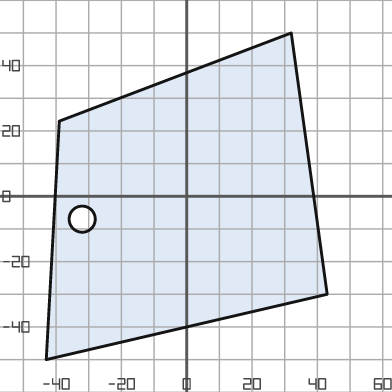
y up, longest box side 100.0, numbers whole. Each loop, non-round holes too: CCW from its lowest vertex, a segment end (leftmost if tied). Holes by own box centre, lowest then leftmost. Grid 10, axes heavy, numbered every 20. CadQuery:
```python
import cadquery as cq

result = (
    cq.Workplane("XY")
    .moveTo(-43.0, -50.0)
    .lineTo(43.0, -30.0)
    .lineTo(32.0, 50.0)
    .lineTo(-39.0, 23.0)
    .close()
    .moveTo(-32.0, -7.0)
    .circle(4.0)
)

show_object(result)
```